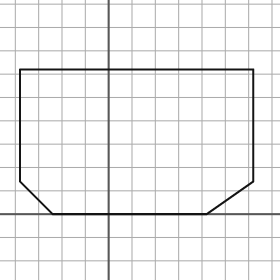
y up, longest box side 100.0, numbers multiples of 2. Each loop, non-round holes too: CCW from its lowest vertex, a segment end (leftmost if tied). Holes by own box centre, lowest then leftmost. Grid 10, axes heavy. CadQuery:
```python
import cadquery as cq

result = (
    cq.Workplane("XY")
    .moveTo(-24.0, 0.0)
    .lineTo(42.0, 0.0)
    .lineTo(62.0, 14.0)
    .lineTo(62.0, 62.0)
    .lineTo(-38.0, 62.0)
    .lineTo(-38.0, 14.0)
    .close()
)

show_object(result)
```